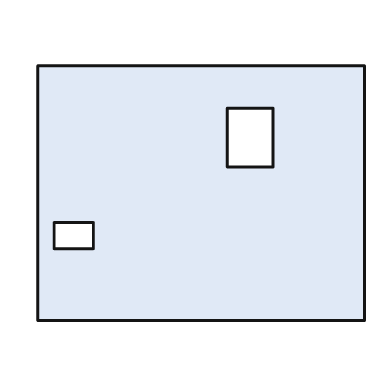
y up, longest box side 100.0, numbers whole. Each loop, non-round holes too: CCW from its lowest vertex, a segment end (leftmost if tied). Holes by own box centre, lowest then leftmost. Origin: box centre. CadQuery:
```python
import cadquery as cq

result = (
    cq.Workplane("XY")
    .moveTo(-50.0, -39.0)
    .lineTo(50.0, -39.0)
    .lineTo(50.0, 39.0)
    .lineTo(-50.0, 39.0)
    .close()
    .moveTo(-45.0, -17.0)
    .lineTo(-33.0, -17.0)
    .lineTo(-33.0, -9.0)
    .lineTo(-45.0, -9.0)
    .close()
    .moveTo(8.0, 8.0)
    .lineTo(22.0, 8.0)
    .lineTo(22.0, 26.0)
    .lineTo(8.0, 26.0)
    .close()
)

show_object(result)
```